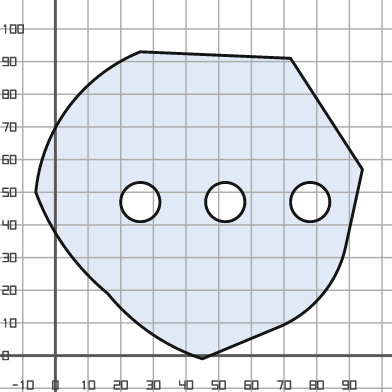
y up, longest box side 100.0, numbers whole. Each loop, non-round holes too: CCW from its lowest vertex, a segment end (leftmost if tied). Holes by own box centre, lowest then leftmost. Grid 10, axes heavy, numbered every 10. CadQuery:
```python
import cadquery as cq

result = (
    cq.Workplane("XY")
    .moveTo(45.0, -1.0)
    .lineTo(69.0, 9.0)
    .threePointArc((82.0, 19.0), (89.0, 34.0))
    .lineTo(94.0, 57.0)
    .lineTo(72.0, 91.0)
    .lineTo(26.0, 93.0)
    .threePointArc((4.0, 76.0), (-6.0, 50.0))
    .threePointArc((3.0, 33.0), (16.0, 19.0))
    .threePointArc((29.0, 7.0), (45.0, -1.0))
    .close()
    .moveTo(26.0, 47.0)
    .circle(6.0)
    .moveTo(52.0, 47.0)
    .circle(6.0)
    .moveTo(78.0, 47.0)
    .circle(6.0)
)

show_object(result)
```